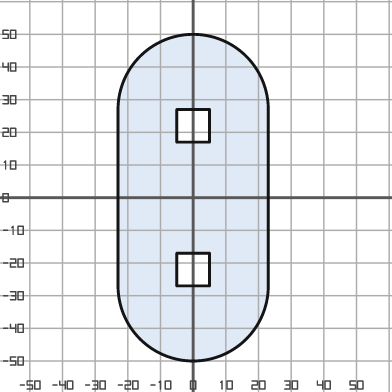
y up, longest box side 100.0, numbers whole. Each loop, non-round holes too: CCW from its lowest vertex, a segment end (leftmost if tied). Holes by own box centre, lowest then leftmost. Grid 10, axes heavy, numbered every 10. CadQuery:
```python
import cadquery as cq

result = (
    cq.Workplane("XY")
    .moveTo(-23.0, -27.0)
    .threePointArc((0.0, -50.0), (23.0, -27.0))
    .lineTo(23.0, 27.0)
    .threePointArc((0.0, 50.0), (-23.0, 27.0))
    .close()
    .moveTo(-5.0, -27.0)
    .lineTo(5.0, -27.0)
    .lineTo(5.0, -17.0)
    .lineTo(-5.0, -17.0)
    .close()
    .moveTo(-5.0, 17.0)
    .lineTo(5.0, 17.0)
    .lineTo(5.0, 27.0)
    .lineTo(-5.0, 27.0)
    .close()
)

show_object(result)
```